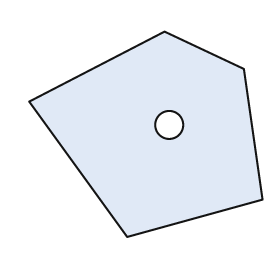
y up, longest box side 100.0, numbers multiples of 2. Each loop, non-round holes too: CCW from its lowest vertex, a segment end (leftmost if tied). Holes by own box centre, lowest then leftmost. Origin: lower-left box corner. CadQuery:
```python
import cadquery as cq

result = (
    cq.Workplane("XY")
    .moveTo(42.0, 0.0)
    .lineTo(100.0, 16.0)
    .lineTo(92.0, 72.0)
    .lineTo(58.0, 88.0)
    .lineTo(0.0, 58.0)
    .close()
    .moveTo(60.0, 48.0)
    .circle(6.0)
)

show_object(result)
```